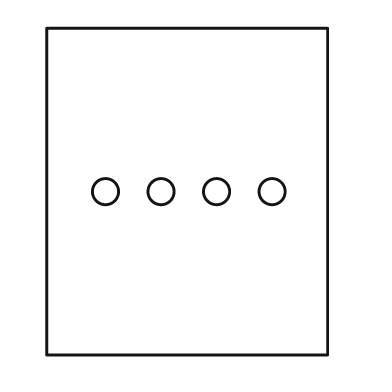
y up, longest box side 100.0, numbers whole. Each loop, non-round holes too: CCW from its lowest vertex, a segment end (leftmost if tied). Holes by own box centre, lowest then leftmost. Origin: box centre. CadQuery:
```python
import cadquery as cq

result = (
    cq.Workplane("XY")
    .moveTo(-43.0, -50.0)
    .lineTo(43.0, -50.0)
    .lineTo(43.0, 50.0)
    .lineTo(-43.0, 50.0)
    .close()
    .moveTo(-25.0, 0.0)
    .circle(4.0)
    .moveTo(-8.0, 0.0)
    .circle(4.0)
    .moveTo(9.0, 0.0)
    .circle(4.0)
    .moveTo(26.0, 0.0)
    .circle(4.0)
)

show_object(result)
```